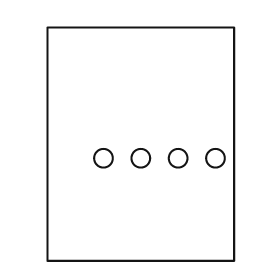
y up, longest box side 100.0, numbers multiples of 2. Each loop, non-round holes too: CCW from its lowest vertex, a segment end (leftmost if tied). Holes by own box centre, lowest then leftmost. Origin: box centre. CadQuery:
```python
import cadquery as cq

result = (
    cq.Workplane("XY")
    .moveTo(-40.0, -50.0)
    .lineTo(40.0, -50.0)
    .lineTo(40.0, 50.0)
    .lineTo(-40.0, 50.0)
    .close()
    .moveTo(-16.0, -6.0)
    .circle(4.0)
    .moveTo(0.0, -6.0)
    .circle(4.0)
    .moveTo(16.0, -6.0)
    .circle(4.0)
    .moveTo(32.0, -6.0)
    .circle(4.0)
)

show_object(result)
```